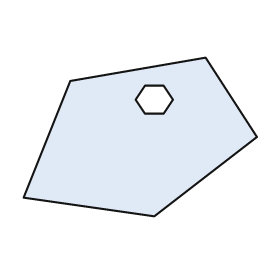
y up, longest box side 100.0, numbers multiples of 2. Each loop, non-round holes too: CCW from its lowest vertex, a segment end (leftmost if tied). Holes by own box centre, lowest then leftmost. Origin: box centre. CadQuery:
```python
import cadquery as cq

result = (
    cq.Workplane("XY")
    .moveTo(6.0, -34.0)
    .lineTo(50.0, 0.0)
    .lineTo(28.0, 34.0)
    .lineTo(-30.0, 24.0)
    .lineTo(-50.0, -26.0)
    .close()
    .moveTo(2.0, 10.0)
    .lineTo(10.0, 10.0)
    .lineTo(14.0, 16.0)
    .lineTo(10.0, 22.0)
    .lineTo(2.0, 22.0)
    .lineTo(-2.0, 16.0)
    .close()
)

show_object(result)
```